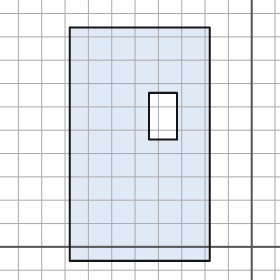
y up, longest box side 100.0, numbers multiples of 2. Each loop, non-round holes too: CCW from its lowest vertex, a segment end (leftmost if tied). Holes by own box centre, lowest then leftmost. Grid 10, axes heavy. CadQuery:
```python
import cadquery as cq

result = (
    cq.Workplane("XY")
    .moveTo(-78.0, -6.0)
    .lineTo(-18.0, -6.0)
    .lineTo(-18.0, 94.0)
    .lineTo(-78.0, 94.0)
    .close()
    .moveTo(-44.0, 46.0)
    .lineTo(-32.0, 46.0)
    .lineTo(-32.0, 66.0)
    .lineTo(-44.0, 66.0)
    .close()
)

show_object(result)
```